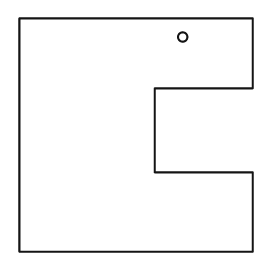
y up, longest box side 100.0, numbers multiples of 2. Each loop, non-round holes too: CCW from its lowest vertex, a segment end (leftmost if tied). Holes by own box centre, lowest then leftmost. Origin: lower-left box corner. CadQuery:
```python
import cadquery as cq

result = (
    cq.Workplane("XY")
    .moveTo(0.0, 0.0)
    .lineTo(100.0, 0.0)
    .lineTo(100.0, 34.0)
    .lineTo(58.0, 34.0)
    .lineTo(58.0, 70.0)
    .lineTo(100.0, 70.0)
    .lineTo(100.0, 100.0)
    .lineTo(0.0, 100.0)
    .close()
    .moveTo(70.0, 92.0)
    .circle(2.0)
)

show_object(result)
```